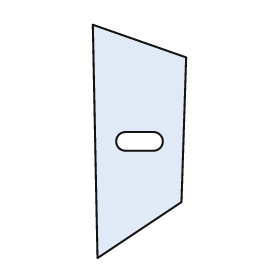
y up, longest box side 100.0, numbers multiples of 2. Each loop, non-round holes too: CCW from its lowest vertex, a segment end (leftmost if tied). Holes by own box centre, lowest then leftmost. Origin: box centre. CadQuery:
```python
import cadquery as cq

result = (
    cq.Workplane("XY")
    .moveTo(-18.0, -50.0)
    .lineTo(18.0, -26.0)
    .lineTo(20.0, 36.0)
    .lineTo(-20.0, 50.0)
    .close()
    .moveTo(-6.0, -4.0)
    .lineTo(6.0, -4.0)
    .threePointArc((10.0, 0.0), (6.0, 4.0))
    .lineTo(-6.0, 4.0)
    .threePointArc((-10.0, 0.0), (-6.0, -4.0))
    .close()
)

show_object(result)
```